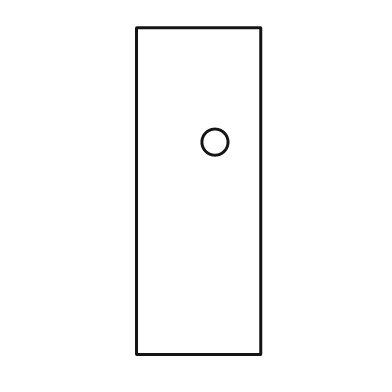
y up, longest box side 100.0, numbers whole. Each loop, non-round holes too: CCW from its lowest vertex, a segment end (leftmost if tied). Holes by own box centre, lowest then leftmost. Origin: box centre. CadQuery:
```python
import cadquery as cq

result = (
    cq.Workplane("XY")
    .moveTo(-19.0, -50.0)
    .lineTo(19.0, -50.0)
    .lineTo(19.0, 50.0)
    .lineTo(-19.0, 50.0)
    .close()
    .moveTo(5.0, 15.0)
    .circle(4.0)
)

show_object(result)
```